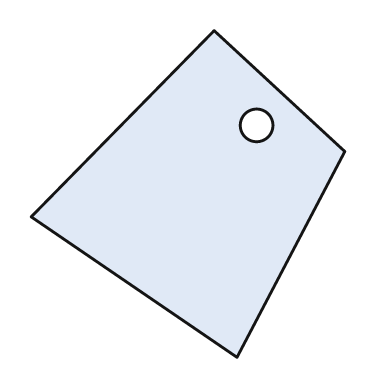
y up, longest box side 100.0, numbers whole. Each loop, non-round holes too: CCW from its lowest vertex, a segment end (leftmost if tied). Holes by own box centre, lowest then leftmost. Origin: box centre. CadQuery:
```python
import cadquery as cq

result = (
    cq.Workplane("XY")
    .moveTo(15.0, -50.0)
    .lineTo(48.0, 13.0)
    .lineTo(8.0, 50.0)
    .lineTo(-48.0, -7.0)
    .close()
    .moveTo(21.0, 21.0)
    .circle(5.0)
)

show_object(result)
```